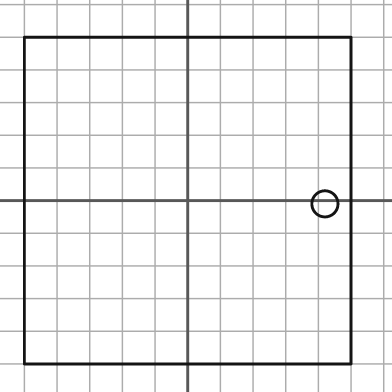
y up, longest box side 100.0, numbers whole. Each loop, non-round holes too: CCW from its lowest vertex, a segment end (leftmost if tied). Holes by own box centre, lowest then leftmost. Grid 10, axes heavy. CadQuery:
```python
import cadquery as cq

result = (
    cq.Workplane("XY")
    .moveTo(-50.0, -50.0)
    .lineTo(50.0, -50.0)
    .lineTo(50.0, 50.0)
    .lineTo(-50.0, 50.0)
    .close()
    .moveTo(42.0, -1.0)
    .circle(4.0)
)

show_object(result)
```